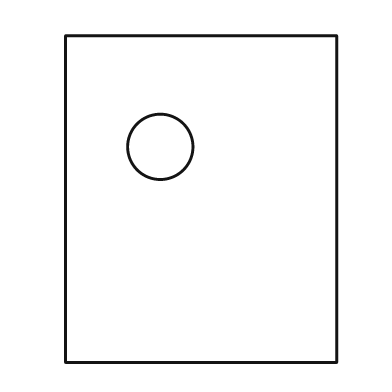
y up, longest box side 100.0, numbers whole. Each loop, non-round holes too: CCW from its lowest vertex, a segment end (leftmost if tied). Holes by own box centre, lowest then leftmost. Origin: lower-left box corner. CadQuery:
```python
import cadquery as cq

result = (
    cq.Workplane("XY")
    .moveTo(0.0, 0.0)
    .lineTo(83.0, 0.0)
    .lineTo(83.0, 100.0)
    .lineTo(0.0, 100.0)
    .close()
    .moveTo(29.0, 66.0)
    .circle(10.0)
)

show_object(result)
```